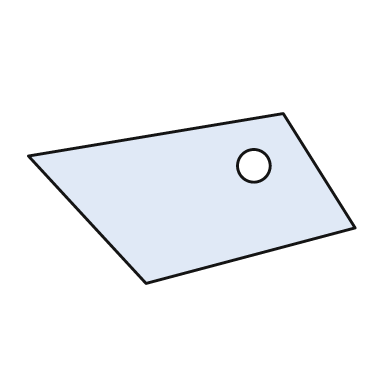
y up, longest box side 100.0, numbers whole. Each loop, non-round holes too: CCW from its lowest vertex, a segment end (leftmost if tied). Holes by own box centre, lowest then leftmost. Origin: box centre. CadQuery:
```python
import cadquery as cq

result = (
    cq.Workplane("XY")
    .moveTo(-14.0, -26.0)
    .lineTo(50.0, -9.0)
    .lineTo(28.0, 26.0)
    .lineTo(-50.0, 13.0)
    .close()
    .moveTo(19.0, 10.0)
    .circle(5.0)
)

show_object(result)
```